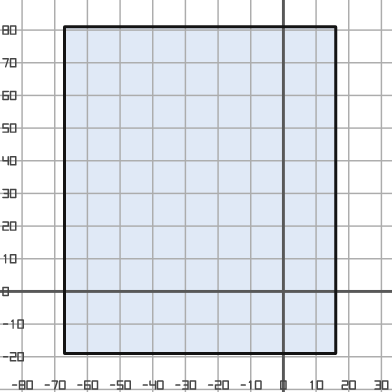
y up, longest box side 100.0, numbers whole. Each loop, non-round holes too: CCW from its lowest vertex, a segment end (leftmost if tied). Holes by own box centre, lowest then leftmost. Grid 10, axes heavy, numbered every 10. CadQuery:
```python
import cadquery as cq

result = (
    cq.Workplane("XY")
    .moveTo(-67.0, -19.0)
    .lineTo(16.0, -19.0)
    .lineTo(16.0, 81.0)
    .lineTo(-67.0, 81.0)
    .close()
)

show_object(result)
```